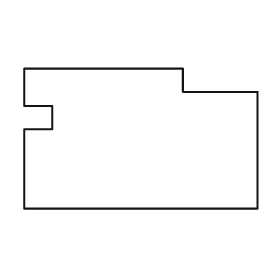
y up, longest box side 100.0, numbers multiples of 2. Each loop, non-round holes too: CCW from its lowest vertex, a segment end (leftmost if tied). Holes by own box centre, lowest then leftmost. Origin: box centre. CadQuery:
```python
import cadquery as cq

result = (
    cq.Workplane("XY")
    .moveTo(-50.0, -30.0)
    .lineTo(50.0, -30.0)
    .lineTo(50.0, 20.0)
    .lineTo(18.0, 20.0)
    .lineTo(18.0, 30.0)
    .lineTo(-50.0, 30.0)
    .lineTo(-50.0, 14.0)
    .lineTo(-38.0, 14.0)
    .lineTo(-38.0, 4.0)
    .lineTo(-50.0, 4.0)
    .close()
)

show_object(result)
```